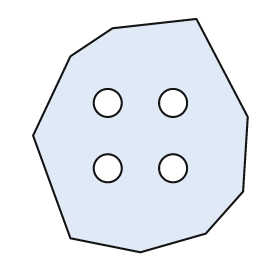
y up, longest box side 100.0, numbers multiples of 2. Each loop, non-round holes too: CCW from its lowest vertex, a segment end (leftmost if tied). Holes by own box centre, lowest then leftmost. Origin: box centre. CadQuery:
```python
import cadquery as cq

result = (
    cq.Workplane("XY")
    .moveTo(0.0, -50.0)
    .lineTo(28.0, -42.0)
    .lineTo(44.0, -24.0)
    .lineTo(46.0, 8.0)
    .lineTo(24.0, 50.0)
    .lineTo(-12.0, 46.0)
    .lineTo(-30.0, 34.0)
    .lineTo(-46.0, 0.0)
    .lineTo(-30.0, -44.0)
    .close()
    .moveTo(-14.0, -14.0)
    .circle(6.0)
    .moveTo(14.0, -14.0)
    .circle(6.0)
    .moveTo(-14.0, 14.0)
    .circle(6.0)
    .moveTo(14.0, 14.0)
    .circle(6.0)
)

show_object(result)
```